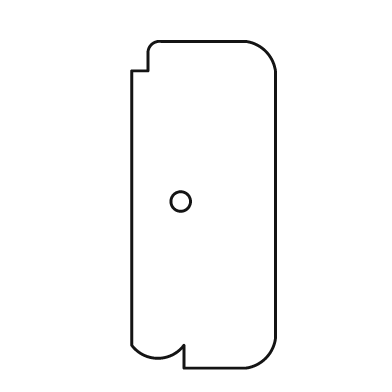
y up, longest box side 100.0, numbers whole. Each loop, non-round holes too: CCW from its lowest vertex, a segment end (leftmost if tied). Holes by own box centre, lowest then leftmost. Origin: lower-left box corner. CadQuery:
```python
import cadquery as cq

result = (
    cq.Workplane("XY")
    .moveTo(16.0, 0.0)
    .lineTo(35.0, 0.0)
    .threePointArc((41.0, 3.0), (44.0, 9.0))
    .lineTo(44.0, 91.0)
    .threePointArc((41.0, 97.0), (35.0, 100.0))
    .lineTo(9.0, 100.0)
    .threePointArc((6.0, 99.0), (5.0, 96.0))
    .lineTo(5.0, 91.0)
    .lineTo(0.0, 91.0)
    .lineTo(0.0, 7.0)
    .threePointArc((8.0, 3.0), (16.0, 7.0))
    .close()
    .moveTo(15.0, 51.0)
    .circle(3.0)
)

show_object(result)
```